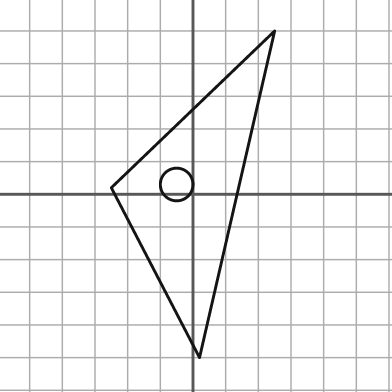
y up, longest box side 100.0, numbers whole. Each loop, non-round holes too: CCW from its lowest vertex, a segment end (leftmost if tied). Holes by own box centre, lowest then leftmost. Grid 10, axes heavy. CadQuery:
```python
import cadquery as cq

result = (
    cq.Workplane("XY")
    .moveTo(2.0, -50.0)
    .lineTo(25.0, 50.0)
    .lineTo(-25.0, 2.0)
    .close()
    .moveTo(-5.0, 3.0)
    .circle(5.0)
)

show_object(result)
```